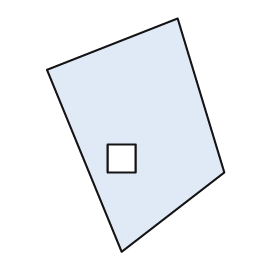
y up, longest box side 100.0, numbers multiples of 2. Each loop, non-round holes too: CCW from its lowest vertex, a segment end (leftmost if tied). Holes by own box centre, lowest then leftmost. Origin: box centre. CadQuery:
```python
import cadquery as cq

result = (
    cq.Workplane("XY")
    .moveTo(-6.0, -50.0)
    .lineTo(38.0, -16.0)
    .lineTo(18.0, 50.0)
    .lineTo(-38.0, 28.0)
    .close()
    .moveTo(-12.0, -16.0)
    .lineTo(0.0, -16.0)
    .lineTo(0.0, -4.0)
    .lineTo(-12.0, -4.0)
    .close()
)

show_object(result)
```